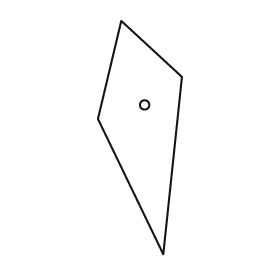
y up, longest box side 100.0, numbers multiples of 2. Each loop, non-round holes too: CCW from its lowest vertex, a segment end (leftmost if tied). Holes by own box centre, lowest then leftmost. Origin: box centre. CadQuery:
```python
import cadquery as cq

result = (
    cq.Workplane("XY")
    .moveTo(10.0, -50.0)
    .lineTo(18.0, 26.0)
    .lineTo(-8.0, 50.0)
    .lineTo(-18.0, 8.0)
    .close()
    .moveTo(2.0, 14.0)
    .circle(2.0)
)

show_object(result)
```